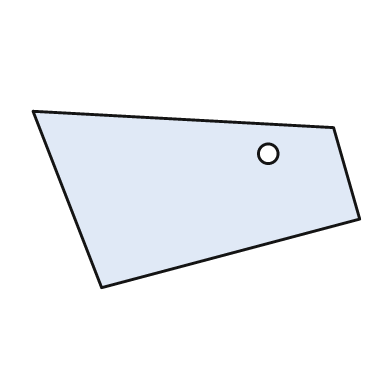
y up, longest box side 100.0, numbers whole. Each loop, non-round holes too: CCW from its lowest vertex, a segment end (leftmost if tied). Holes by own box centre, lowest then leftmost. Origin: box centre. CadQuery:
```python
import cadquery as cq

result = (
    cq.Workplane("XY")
    .moveTo(-29.0, -27.0)
    .lineTo(50.0, -6.0)
    .lineTo(42.0, 22.0)
    .lineTo(-50.0, 27.0)
    .close()
    .moveTo(22.0, 14.0)
    .circle(3.0)
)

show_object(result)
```